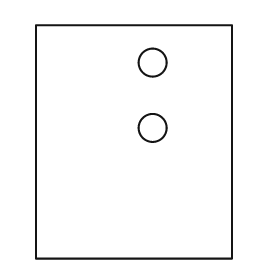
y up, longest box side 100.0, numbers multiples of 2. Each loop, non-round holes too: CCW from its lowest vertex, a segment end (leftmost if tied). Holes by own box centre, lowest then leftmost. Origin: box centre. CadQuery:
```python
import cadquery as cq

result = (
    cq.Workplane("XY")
    .moveTo(-42.0, -50.0)
    .lineTo(42.0, -50.0)
    .lineTo(42.0, 50.0)
    .lineTo(-42.0, 50.0)
    .close()
    .moveTo(8.0, 6.0)
    .circle(6.0)
    .moveTo(8.0, 34.0)
    .circle(6.0)
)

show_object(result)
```